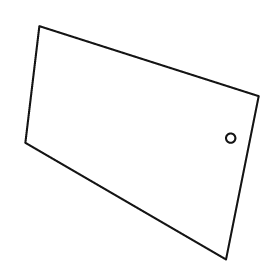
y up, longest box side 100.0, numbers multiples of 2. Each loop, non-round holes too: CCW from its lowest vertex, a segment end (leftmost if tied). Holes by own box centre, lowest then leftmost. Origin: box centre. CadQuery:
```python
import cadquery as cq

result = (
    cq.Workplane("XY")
    .moveTo(36.0, -50.0)
    .lineTo(50.0, 20.0)
    .lineTo(-44.0, 50.0)
    .lineTo(-50.0, 0.0)
    .close()
    .moveTo(38.0, 2.0)
    .circle(2.0)
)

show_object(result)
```